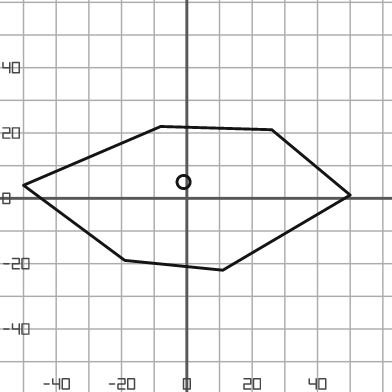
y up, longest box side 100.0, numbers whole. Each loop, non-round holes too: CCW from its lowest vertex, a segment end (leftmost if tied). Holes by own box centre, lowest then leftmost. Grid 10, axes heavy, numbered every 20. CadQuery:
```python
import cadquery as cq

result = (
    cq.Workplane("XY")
    .moveTo(11.0, -22.0)
    .lineTo(50.0, 1.0)
    .lineTo(26.0, 21.0)
    .lineTo(-8.0, 22.0)
    .lineTo(-50.0, 4.0)
    .lineTo(-19.0, -19.0)
    .close()
    .moveTo(-1.0, 5.0)
    .circle(2.0)
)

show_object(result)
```